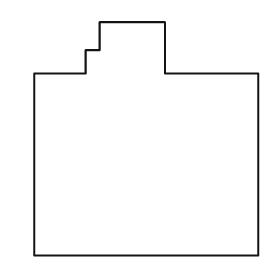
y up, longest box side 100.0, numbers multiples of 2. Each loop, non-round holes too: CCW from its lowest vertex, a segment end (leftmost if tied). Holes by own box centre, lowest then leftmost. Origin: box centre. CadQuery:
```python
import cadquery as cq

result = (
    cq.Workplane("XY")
    .moveTo(-48.0, -50.0)
    .lineTo(48.0, -50.0)
    .lineTo(48.0, 28.0)
    .lineTo(8.0, 28.0)
    .lineTo(8.0, 50.0)
    .lineTo(-20.0, 50.0)
    .lineTo(-20.0, 38.0)
    .lineTo(-26.0, 38.0)
    .lineTo(-26.0, 28.0)
    .lineTo(-48.0, 28.0)
    .close()
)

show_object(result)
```